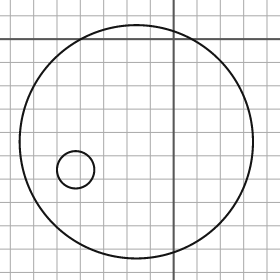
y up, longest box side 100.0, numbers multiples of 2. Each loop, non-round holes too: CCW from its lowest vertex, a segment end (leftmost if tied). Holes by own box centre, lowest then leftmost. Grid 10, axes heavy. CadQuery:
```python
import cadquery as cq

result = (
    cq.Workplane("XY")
    .moveTo(-16.0, -44.0)
    .circle(50.0)
    .moveTo(-42.0, -56.0)
    .circle(8.0)
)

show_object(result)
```